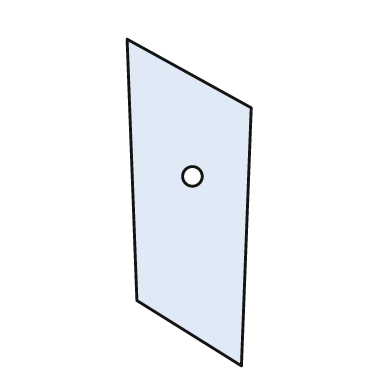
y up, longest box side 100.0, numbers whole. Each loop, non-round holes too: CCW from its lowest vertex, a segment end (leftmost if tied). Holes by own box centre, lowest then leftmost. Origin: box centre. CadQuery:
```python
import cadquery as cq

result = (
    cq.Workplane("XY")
    .moveTo(16.0, -50.0)
    .lineTo(19.0, 29.0)
    .lineTo(-19.0, 50.0)
    .lineTo(-16.0, -30.0)
    .close()
    .moveTo(1.0, 8.0)
    .circle(3.0)
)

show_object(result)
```